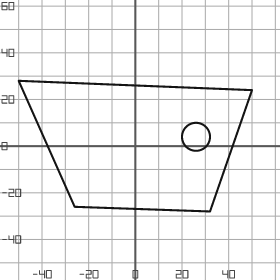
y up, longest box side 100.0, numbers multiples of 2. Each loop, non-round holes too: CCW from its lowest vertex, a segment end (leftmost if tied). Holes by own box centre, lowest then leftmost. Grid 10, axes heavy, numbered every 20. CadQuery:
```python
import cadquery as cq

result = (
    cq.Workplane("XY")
    .moveTo(32.0, -28.0)
    .lineTo(50.0, 24.0)
    .lineTo(-50.0, 28.0)
    .lineTo(-26.0, -26.0)
    .close()
    .moveTo(26.0, 4.0)
    .circle(6.0)
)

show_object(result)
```